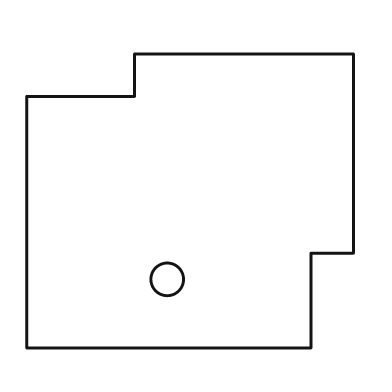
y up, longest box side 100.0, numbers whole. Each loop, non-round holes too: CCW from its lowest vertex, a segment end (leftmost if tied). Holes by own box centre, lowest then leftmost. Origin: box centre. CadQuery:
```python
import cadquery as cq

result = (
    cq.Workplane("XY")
    .moveTo(-50.0, -45.0)
    .lineTo(37.0, -45.0)
    .lineTo(37.0, -16.0)
    .lineTo(50.0, -16.0)
    .lineTo(50.0, 45.0)
    .lineTo(-17.0, 45.0)
    .lineTo(-17.0, 32.0)
    .lineTo(-50.0, 32.0)
    .close()
    .moveTo(-7.0, -24.0)
    .circle(5.0)
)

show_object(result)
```